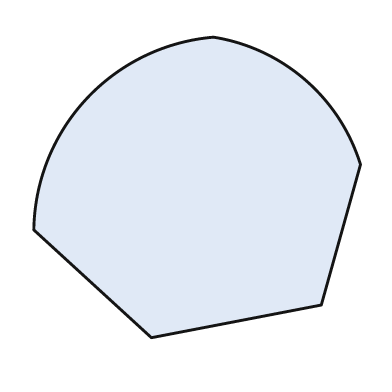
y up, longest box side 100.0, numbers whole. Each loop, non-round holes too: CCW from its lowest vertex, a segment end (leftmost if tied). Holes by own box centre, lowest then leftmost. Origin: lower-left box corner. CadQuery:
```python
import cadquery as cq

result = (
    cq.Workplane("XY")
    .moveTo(36.0, 0.0)
    .lineTo(88.0, 10.0)
    .lineTo(100.0, 53.0)
    .threePointArc((83.0, 79.0), (55.0, 92.0))
    .threePointArc((16.0, 73.0), (0.0, 33.0))
    .close()
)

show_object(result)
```